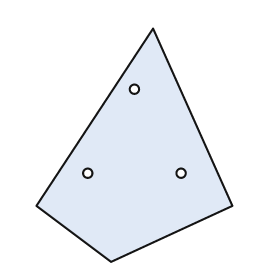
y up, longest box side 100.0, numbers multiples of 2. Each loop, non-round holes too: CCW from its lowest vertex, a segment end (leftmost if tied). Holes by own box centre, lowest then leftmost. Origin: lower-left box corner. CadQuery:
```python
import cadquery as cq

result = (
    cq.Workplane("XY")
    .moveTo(32.0, 0.0)
    .lineTo(84.0, 24.0)
    .lineTo(50.0, 100.0)
    .lineTo(0.0, 24.0)
    .close()
    .moveTo(22.0, 38.0)
    .circle(2.0)
    .moveTo(62.0, 38.0)
    .circle(2.0)
    .moveTo(42.0, 74.0)
    .circle(2.0)
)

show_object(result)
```